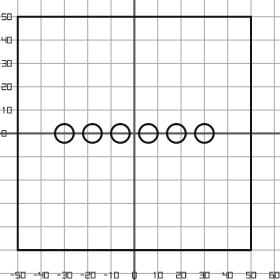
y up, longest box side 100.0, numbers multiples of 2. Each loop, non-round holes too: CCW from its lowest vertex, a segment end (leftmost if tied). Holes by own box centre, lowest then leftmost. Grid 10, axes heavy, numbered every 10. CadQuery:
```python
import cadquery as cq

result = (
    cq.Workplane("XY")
    .moveTo(-50.0, -50.0)
    .lineTo(50.0, -50.0)
    .lineTo(50.0, 50.0)
    .lineTo(-50.0, 50.0)
    .close()
    .moveTo(-30.0, 0.0)
    .circle(4.0)
    .moveTo(-18.0, 0.0)
    .circle(4.0)
    .moveTo(-6.0, 0.0)
    .circle(4.0)
    .moveTo(6.0, 0.0)
    .circle(4.0)
    .moveTo(18.0, 0.0)
    .circle(4.0)
    .moveTo(30.0, 0.0)
    .circle(4.0)
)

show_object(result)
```